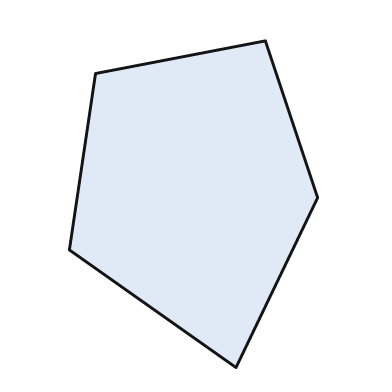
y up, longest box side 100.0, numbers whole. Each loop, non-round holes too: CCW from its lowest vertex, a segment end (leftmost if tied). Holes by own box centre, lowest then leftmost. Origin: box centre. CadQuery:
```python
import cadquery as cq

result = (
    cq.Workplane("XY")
    .moveTo(13.0, -50.0)
    .lineTo(38.0, 2.0)
    .lineTo(22.0, 50.0)
    .lineTo(-30.0, 40.0)
    .lineTo(-38.0, -14.0)
    .close()
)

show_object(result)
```